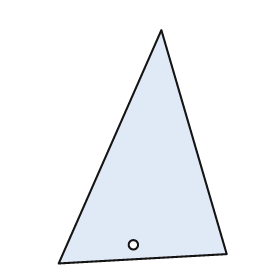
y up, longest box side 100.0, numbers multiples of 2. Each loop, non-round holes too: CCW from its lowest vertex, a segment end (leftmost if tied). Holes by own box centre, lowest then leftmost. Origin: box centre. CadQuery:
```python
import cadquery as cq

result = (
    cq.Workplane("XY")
    .moveTo(-36.0, -50.0)
    .lineTo(36.0, -46.0)
    .lineTo(8.0, 50.0)
    .close()
    .moveTo(-4.0, -42.0)
    .circle(2.0)
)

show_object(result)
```